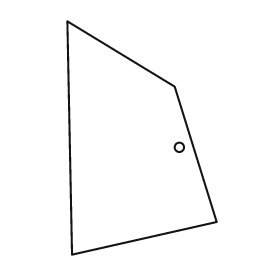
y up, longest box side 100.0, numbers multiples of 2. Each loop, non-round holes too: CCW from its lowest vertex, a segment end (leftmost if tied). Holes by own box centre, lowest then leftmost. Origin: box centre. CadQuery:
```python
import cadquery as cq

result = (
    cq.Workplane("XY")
    .moveTo(-30.0, -50.0)
    .lineTo(32.0, -36.0)
    .lineTo(14.0, 22.0)
    .lineTo(-32.0, 50.0)
    .close()
    .moveTo(16.0, -4.0)
    .circle(2.0)
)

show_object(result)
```